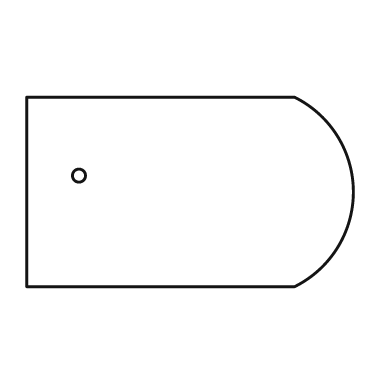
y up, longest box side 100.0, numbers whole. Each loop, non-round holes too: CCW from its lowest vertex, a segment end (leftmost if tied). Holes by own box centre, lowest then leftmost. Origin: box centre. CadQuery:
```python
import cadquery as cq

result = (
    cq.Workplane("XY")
    .moveTo(-50.0, -29.0)
    .lineTo(32.0, -29.0)
    .threePointArc((50.0, 0.0), (32.0, 29.0))
    .lineTo(-50.0, 29.0)
    .close()
    .moveTo(-34.0, 5.0)
    .circle(2.0)
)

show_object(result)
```